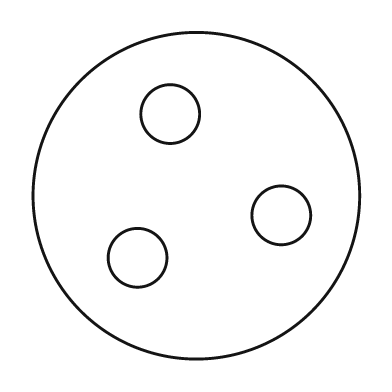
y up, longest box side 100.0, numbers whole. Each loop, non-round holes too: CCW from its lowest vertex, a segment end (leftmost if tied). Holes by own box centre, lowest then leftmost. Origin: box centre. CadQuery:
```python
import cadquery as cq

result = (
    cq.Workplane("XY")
    .moveTo(0.0, 0.0)
    .circle(50.0)
    .moveTo(-18.0, -19.0)
    .circle(9.0)
    .moveTo(26.0, -6.0)
    .circle(9.0)
    .moveTo(-8.0, 25.0)
    .circle(9.0)
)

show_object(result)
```